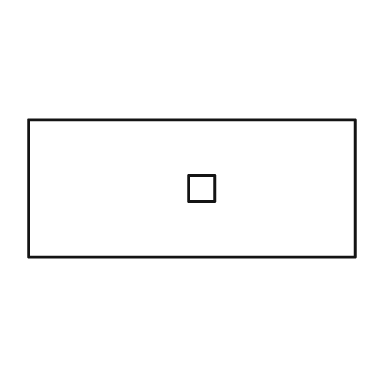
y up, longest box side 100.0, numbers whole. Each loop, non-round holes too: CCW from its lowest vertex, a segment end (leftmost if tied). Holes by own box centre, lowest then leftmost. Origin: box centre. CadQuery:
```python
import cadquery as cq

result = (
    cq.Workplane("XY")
    .moveTo(-50.0, -21.0)
    .lineTo(50.0, -21.0)
    .lineTo(50.0, 21.0)
    .lineTo(-50.0, 21.0)
    .close()
    .moveTo(-1.0, -4.0)
    .lineTo(7.0, -4.0)
    .lineTo(7.0, 4.0)
    .lineTo(-1.0, 4.0)
    .close()
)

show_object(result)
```